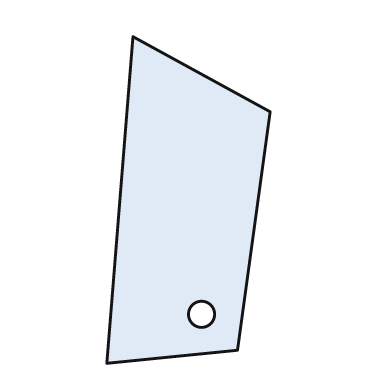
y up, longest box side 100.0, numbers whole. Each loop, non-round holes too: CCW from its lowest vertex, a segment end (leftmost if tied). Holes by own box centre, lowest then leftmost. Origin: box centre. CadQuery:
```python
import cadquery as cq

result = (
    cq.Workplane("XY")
    .moveTo(-25.0, -50.0)
    .lineTo(15.0, -46.0)
    .lineTo(25.0, 27.0)
    .lineTo(-17.0, 50.0)
    .close()
    .moveTo(4.0, -35.0)
    .circle(4.0)
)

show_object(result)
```